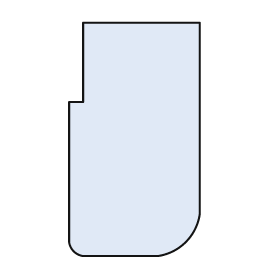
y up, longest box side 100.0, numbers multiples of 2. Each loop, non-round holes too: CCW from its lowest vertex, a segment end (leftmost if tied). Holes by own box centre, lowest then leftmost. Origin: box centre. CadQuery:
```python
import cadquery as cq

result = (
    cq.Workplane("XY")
    .moveTo(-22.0, -50.0)
    .lineTo(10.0, -50.0)
    .threePointArc((22.0, -44.0), (28.0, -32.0))
    .lineTo(28.0, 50.0)
    .lineTo(-22.0, 50.0)
    .lineTo(-22.0, 16.0)
    .lineTo(-28.0, 16.0)
    .lineTo(-28.0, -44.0)
    .threePointArc((-26.0, -48.0), (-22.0, -50.0))
    .close()
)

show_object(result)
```